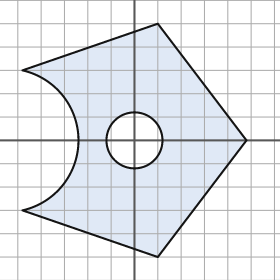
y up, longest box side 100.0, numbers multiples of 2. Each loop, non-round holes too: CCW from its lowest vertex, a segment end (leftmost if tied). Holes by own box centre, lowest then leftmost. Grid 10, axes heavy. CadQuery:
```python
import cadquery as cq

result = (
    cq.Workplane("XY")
    .moveTo(10.0, -50.0)
    .lineTo(48.0, 0.0)
    .lineTo(10.0, 50.0)
    .lineTo(-48.0, 30.0)
    .threePointArc((-24.0, 0.0), (-48.0, -30.0))
    .close()
    .moveTo(0.0, 0.0)
    .circle(12.0)
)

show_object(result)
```